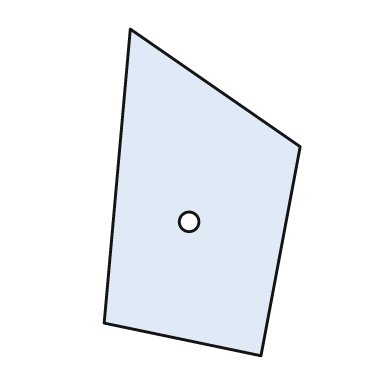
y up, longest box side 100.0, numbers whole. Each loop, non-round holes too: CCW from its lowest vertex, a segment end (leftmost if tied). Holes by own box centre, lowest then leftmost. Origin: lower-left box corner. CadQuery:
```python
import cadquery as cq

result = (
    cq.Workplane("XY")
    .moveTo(48.0, 0.0)
    .lineTo(60.0, 64.0)
    .lineTo(8.0, 100.0)
    .lineTo(0.0, 10.0)
    .close()
    .moveTo(26.0, 41.0)
    .circle(3.0)
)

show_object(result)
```